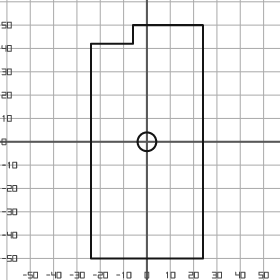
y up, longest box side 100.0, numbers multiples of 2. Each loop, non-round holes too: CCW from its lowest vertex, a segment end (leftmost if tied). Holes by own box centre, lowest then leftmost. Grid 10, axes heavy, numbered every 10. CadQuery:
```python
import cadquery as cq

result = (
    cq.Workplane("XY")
    .moveTo(-24.0, -50.0)
    .lineTo(24.0, -50.0)
    .lineTo(24.0, 50.0)
    .lineTo(-6.0, 50.0)
    .lineTo(-6.0, 42.0)
    .lineTo(-24.0, 42.0)
    .close()
    .moveTo(0.0, 0.0)
    .circle(4.0)
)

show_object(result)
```